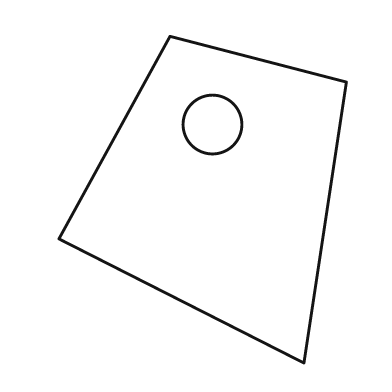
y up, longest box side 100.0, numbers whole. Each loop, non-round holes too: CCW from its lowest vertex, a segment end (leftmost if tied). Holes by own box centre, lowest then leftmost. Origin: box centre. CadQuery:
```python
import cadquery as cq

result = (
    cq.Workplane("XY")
    .moveTo(31.0, -50.0)
    .lineTo(44.0, 36.0)
    .lineTo(-10.0, 50.0)
    .lineTo(-44.0, -12.0)
    .close()
    .moveTo(3.0, 23.0)
    .circle(9.0)
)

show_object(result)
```